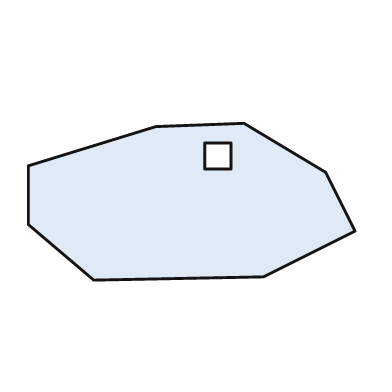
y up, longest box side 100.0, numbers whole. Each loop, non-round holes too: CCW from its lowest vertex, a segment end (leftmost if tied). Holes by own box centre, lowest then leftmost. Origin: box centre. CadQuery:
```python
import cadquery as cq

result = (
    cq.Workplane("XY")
    .moveTo(-30.0, -24.0)
    .lineTo(22.0, -23.0)
    .lineTo(50.0, -9.0)
    .lineTo(41.0, 9.0)
    .lineTo(16.0, 24.0)
    .lineTo(-11.0, 23.0)
    .lineTo(-50.0, 11.0)
    .lineTo(-50.0, -7.0)
    .close()
    .moveTo(4.0, 10.0)
    .lineTo(12.0, 10.0)
    .lineTo(12.0, 18.0)
    .lineTo(4.0, 18.0)
    .close()
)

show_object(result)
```